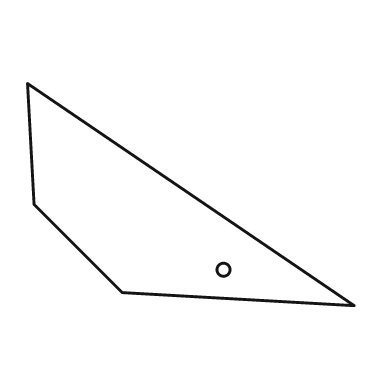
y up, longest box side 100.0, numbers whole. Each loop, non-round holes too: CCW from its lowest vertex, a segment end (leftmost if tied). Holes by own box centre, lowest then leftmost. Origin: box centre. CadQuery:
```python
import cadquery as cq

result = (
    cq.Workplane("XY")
    .moveTo(50.0, -34.0)
    .lineTo(-50.0, 34.0)
    .lineTo(-48.0, -3.0)
    .lineTo(-21.0, -30.0)
    .close()
    .moveTo(10.0, -23.0)
    .circle(2.0)
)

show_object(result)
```